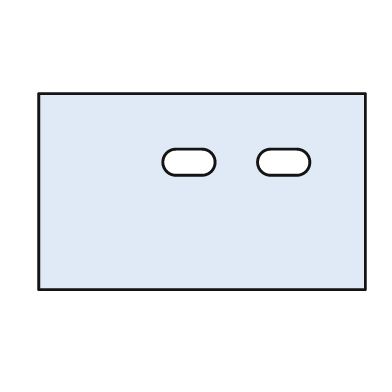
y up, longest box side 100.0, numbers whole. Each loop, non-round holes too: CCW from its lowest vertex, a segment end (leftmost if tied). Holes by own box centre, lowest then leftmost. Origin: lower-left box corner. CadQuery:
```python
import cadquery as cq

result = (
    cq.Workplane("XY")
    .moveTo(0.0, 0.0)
    .lineTo(100.0, 0.0)
    .lineTo(100.0, 60.0)
    .lineTo(0.0, 60.0)
    .close()
    .moveTo(42.0, 35.0)
    .lineTo(50.0, 35.0)
    .threePointArc((54.0, 39.0), (50.0, 43.0))
    .lineTo(42.0, 43.0)
    .threePointArc((38.0, 39.0), (42.0, 35.0))
    .close()
    .moveTo(71.0, 35.0)
    .lineTo(79.0, 35.0)
    .threePointArc((83.0, 39.0), (79.0, 43.0))
    .lineTo(71.0, 43.0)
    .threePointArc((67.0, 39.0), (71.0, 35.0))
    .close()
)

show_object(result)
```